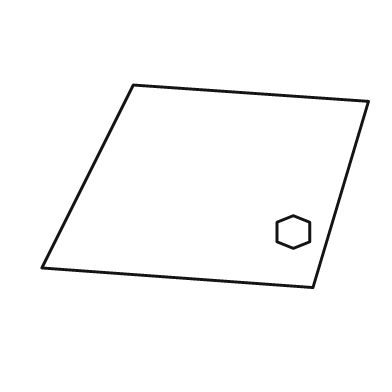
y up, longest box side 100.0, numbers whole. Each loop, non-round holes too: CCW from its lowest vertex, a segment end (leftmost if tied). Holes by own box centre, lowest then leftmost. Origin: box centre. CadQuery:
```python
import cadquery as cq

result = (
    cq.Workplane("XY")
    .moveTo(33.0, -31.0)
    .lineTo(50.0, 26.0)
    .lineTo(-22.0, 31.0)
    .lineTo(-50.0, -25.0)
    .close()
    .moveTo(27.0, -19.0)
    .lineTo(32.0, -17.0)
    .lineTo(32.0, -11.0)
    .lineTo(27.0, -9.0)
    .lineTo(22.0, -11.0)
    .lineTo(22.0, -17.0)
    .close()
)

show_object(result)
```